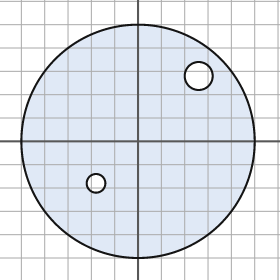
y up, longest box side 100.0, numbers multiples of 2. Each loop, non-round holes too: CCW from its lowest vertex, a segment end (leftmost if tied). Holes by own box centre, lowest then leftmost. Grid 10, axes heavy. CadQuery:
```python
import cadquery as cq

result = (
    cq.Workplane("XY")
    .moveTo(0.0, 0.0)
    .circle(50.0)
    .moveTo(-18.0, -18.0)
    .circle(4.0)
    .moveTo(26.0, 28.0)
    .circle(6.0)
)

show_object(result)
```